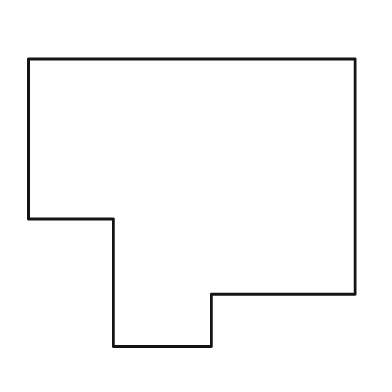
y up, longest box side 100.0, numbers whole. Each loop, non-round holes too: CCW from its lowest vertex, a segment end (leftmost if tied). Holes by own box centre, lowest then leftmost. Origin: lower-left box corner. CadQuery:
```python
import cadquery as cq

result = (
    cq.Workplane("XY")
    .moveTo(26.0, 0.0)
    .lineTo(56.0, 0.0)
    .lineTo(56.0, 16.0)
    .lineTo(100.0, 16.0)
    .lineTo(100.0, 88.0)
    .lineTo(0.0, 88.0)
    .lineTo(0.0, 39.0)
    .lineTo(26.0, 39.0)
    .close()
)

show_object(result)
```